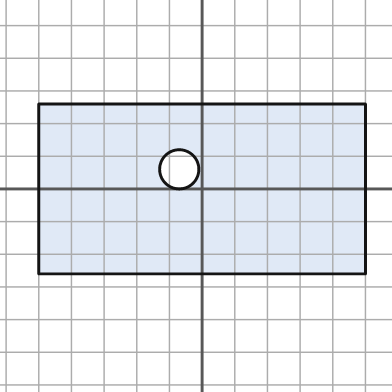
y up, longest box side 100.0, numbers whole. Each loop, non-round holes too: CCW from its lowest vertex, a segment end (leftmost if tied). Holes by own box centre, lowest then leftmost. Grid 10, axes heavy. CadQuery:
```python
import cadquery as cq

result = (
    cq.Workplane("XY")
    .moveTo(-50.0, -26.0)
    .lineTo(50.0, -26.0)
    .lineTo(50.0, 26.0)
    .lineTo(-50.0, 26.0)
    .close()
    .moveTo(-7.0, 6.0)
    .circle(6.0)
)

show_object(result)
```